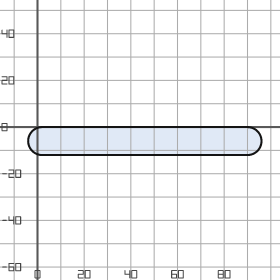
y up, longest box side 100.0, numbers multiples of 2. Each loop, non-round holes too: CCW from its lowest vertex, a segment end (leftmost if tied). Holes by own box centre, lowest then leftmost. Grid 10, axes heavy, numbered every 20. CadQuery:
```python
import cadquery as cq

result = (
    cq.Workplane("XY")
    .moveTo(2.0, -12.0)
    .lineTo(90.0, -12.0)
    .threePointArc((96.0, -6.0), (90.0, 0.0))
    .lineTo(2.0, 0.0)
    .threePointArc((-4.0, -6.0), (2.0, -12.0))
    .close()
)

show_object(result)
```